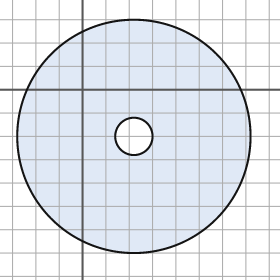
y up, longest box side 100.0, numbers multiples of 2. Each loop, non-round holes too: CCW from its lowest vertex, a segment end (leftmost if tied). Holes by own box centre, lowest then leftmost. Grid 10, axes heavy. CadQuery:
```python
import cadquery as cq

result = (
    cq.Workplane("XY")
    .moveTo(22.0, -20.0)
    .circle(50.0)
    .moveTo(22.0, -20.0)
    .circle(8.0)
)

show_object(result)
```